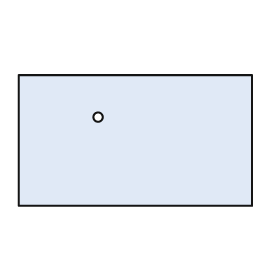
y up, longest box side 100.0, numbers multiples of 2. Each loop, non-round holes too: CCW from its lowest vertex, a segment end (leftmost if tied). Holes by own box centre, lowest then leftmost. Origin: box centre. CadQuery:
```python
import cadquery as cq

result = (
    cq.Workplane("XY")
    .moveTo(-50.0, -28.0)
    .lineTo(50.0, -28.0)
    .lineTo(50.0, 28.0)
    .lineTo(-50.0, 28.0)
    .close()
    .moveTo(-16.0, 10.0)
    .circle(2.0)
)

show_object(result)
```